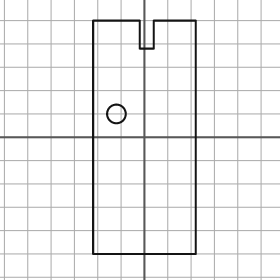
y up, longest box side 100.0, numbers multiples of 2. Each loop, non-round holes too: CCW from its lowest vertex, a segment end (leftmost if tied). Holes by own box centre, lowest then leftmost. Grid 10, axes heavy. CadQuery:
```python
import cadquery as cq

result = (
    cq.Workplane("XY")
    .moveTo(-22.0, -50.0)
    .lineTo(22.0, -50.0)
    .lineTo(22.0, 50.0)
    .lineTo(4.0, 50.0)
    .lineTo(4.0, 38.0)
    .lineTo(-2.0, 38.0)
    .lineTo(-2.0, 50.0)
    .lineTo(-22.0, 50.0)
    .close()
    .moveTo(-12.0, 10.0)
    .circle(4.0)
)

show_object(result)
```